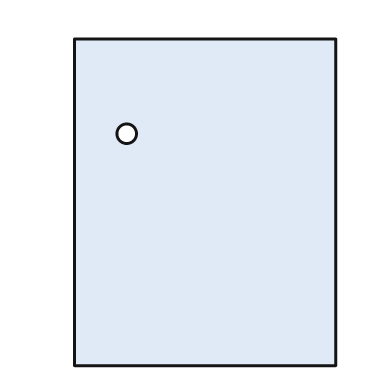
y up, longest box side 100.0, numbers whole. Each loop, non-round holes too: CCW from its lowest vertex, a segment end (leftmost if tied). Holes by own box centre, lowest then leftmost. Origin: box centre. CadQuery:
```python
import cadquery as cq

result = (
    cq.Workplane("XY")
    .moveTo(-40.0, -50.0)
    .lineTo(40.0, -50.0)
    .lineTo(40.0, 50.0)
    .lineTo(-40.0, 50.0)
    .close()
    .moveTo(-24.0, 21.0)
    .circle(3.0)
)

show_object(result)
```